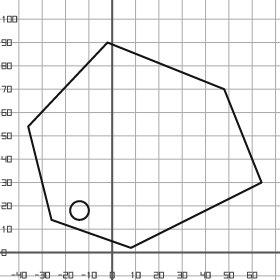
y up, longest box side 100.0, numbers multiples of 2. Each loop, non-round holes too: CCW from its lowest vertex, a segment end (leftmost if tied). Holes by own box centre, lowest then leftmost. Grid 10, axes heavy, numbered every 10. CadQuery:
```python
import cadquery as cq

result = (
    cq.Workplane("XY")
    .moveTo(8.0, 2.0)
    .lineTo(64.0, 30.0)
    .lineTo(48.0, 70.0)
    .lineTo(-2.0, 90.0)
    .lineTo(-36.0, 54.0)
    .lineTo(-26.0, 14.0)
    .close()
    .moveTo(-14.0, 18.0)
    .circle(4.0)
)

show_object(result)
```